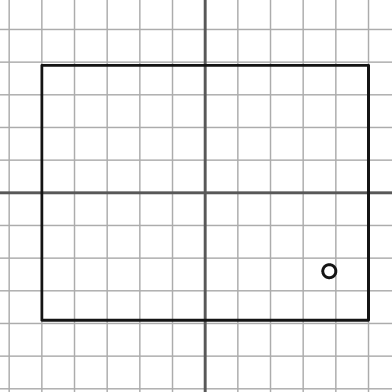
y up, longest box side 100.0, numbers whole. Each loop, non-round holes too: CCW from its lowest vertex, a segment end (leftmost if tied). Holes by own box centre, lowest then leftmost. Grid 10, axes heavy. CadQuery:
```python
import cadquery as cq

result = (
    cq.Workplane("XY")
    .moveTo(-50.0, -39.0)
    .lineTo(50.0, -39.0)
    .lineTo(50.0, 39.0)
    .lineTo(-50.0, 39.0)
    .close()
    .moveTo(38.0, -24.0)
    .circle(2.0)
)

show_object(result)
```